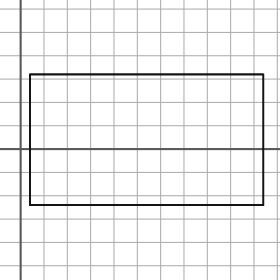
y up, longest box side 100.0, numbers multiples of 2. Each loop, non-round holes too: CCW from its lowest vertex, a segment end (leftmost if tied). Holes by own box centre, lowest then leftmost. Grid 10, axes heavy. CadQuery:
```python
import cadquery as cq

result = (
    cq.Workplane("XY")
    .moveTo(4.0, -24.0)
    .lineTo(104.0, -24.0)
    .lineTo(104.0, 32.0)
    .lineTo(4.0, 32.0)
    .close()
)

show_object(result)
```